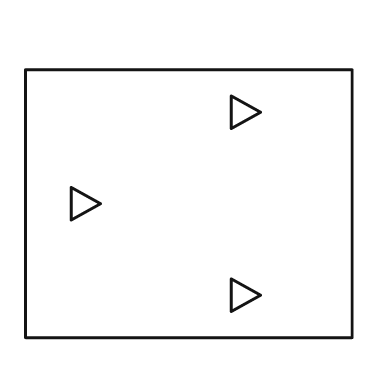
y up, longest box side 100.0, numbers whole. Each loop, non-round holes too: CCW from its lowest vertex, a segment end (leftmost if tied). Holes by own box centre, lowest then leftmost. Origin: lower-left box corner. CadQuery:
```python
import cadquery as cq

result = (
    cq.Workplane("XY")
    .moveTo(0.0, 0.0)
    .lineTo(100.0, 0.0)
    .lineTo(100.0, 82.0)
    .lineTo(0.0, 82.0)
    .close()
    .moveTo(63.0, 8.0)
    .lineTo(72.0, 13.0)
    .lineTo(63.0, 18.0)
    .close()
    .moveTo(14.0, 36.0)
    .lineTo(23.0, 41.0)
    .lineTo(14.0, 46.0)
    .close()
    .moveTo(63.0, 64.0)
    .lineTo(72.0, 69.0)
    .lineTo(63.0, 74.0)
    .close()
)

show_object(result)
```